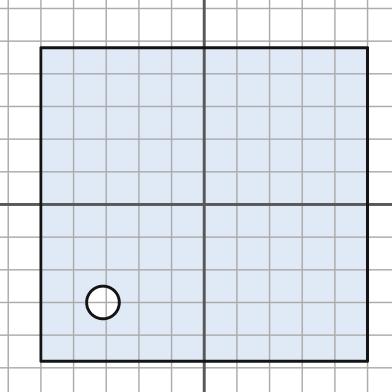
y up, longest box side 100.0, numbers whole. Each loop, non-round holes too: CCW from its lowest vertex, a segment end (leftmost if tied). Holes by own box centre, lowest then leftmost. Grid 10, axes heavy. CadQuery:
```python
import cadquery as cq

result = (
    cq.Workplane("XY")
    .moveTo(-50.0, -48.0)
    .lineTo(50.0, -48.0)
    .lineTo(50.0, 48.0)
    .lineTo(-50.0, 48.0)
    .close()
    .moveTo(-31.0, -30.0)
    .circle(5.0)
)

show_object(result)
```